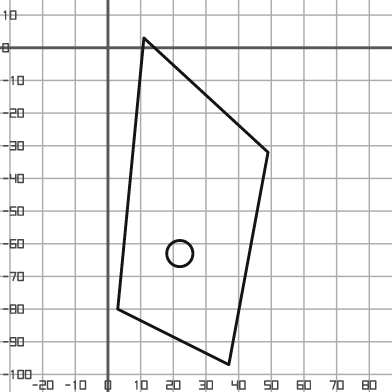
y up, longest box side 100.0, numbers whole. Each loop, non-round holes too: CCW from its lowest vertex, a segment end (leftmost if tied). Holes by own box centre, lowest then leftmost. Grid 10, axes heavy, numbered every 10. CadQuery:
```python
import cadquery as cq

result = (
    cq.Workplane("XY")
    .moveTo(37.0, -97.0)
    .lineTo(49.0, -32.0)
    .lineTo(11.0, 3.0)
    .lineTo(3.0, -80.0)
    .close()
    .moveTo(22.0, -63.0)
    .circle(4.0)
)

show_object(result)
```